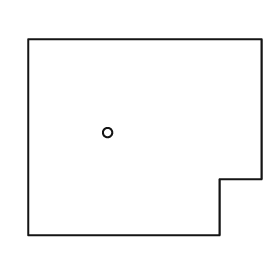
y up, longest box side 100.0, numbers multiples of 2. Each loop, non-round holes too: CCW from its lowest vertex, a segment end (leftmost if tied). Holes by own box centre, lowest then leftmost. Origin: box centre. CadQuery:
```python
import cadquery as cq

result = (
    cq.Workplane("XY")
    .moveTo(-50.0, -42.0)
    .lineTo(32.0, -42.0)
    .lineTo(32.0, -18.0)
    .lineTo(50.0, -18.0)
    .lineTo(50.0, 42.0)
    .lineTo(-50.0, 42.0)
    .close()
    .moveTo(-16.0, 2.0)
    .circle(2.0)
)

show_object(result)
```